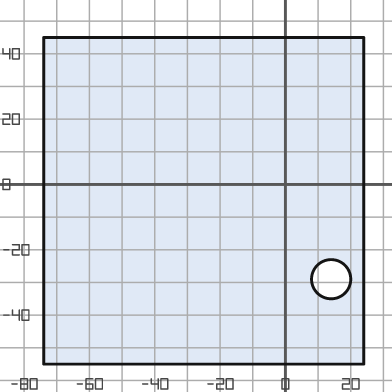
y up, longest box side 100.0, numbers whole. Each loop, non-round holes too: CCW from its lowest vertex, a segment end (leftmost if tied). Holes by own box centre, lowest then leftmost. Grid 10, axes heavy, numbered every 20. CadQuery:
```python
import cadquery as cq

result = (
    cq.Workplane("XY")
    .moveTo(-74.0, -55.0)
    .lineTo(24.0, -55.0)
    .lineTo(24.0, 45.0)
    .lineTo(-74.0, 45.0)
    .close()
    .moveTo(14.0, -29.0)
    .circle(6.0)
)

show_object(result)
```